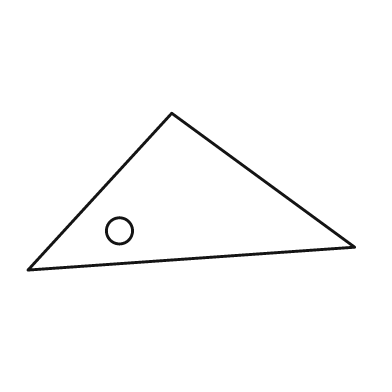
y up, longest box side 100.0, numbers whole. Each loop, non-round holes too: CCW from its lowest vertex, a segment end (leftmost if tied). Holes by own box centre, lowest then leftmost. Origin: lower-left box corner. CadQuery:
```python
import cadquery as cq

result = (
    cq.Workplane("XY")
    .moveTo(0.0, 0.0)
    .lineTo(100.0, 7.0)
    .lineTo(44.0, 48.0)
    .close()
    .moveTo(28.0, 12.0)
    .circle(4.0)
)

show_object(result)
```